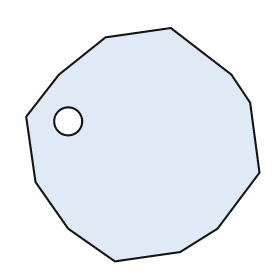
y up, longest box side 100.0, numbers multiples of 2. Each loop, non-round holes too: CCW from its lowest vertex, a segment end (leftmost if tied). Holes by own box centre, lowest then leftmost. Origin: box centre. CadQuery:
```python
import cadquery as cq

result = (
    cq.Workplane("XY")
    .moveTo(-12.0, -50.0)
    .lineTo(16.0, -46.0)
    .lineTo(32.0, -36.0)
    .lineTo(50.0, -12.0)
    .lineTo(46.0, 18.0)
    .lineTo(38.0, 30.0)
    .lineTo(12.0, 50.0)
    .lineTo(-16.0, 46.0)
    .lineTo(-36.0, 30.0)
    .lineTo(-50.0, 12.0)
    .lineTo(-46.0, -16.0)
    .lineTo(-32.0, -36.0)
    .close()
    .moveTo(-32.0, 10.0)
    .circle(6.0)
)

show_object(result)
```